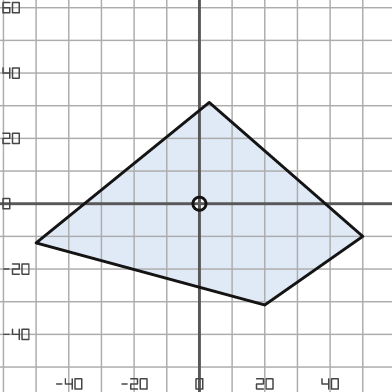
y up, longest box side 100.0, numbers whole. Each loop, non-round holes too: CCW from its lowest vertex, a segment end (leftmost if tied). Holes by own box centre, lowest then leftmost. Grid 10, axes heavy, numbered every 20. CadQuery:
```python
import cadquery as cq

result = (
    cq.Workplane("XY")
    .moveTo(20.0, -31.0)
    .lineTo(50.0, -10.0)
    .lineTo(3.0, 31.0)
    .lineTo(-50.0, -12.0)
    .close()
    .moveTo(0.0, 0.0)
    .circle(2.0)
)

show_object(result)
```